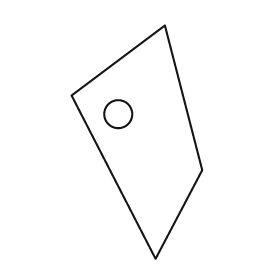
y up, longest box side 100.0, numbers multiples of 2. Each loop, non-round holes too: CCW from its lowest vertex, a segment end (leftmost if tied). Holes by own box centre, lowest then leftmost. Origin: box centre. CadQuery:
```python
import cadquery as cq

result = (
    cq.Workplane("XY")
    .moveTo(8.0, -50.0)
    .lineTo(28.0, -12.0)
    .lineTo(12.0, 50.0)
    .lineTo(-28.0, 20.0)
    .close()
    .moveTo(-8.0, 12.0)
    .circle(6.0)
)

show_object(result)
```